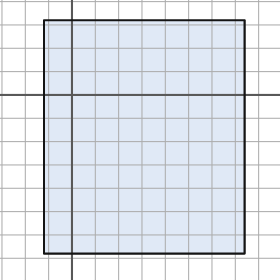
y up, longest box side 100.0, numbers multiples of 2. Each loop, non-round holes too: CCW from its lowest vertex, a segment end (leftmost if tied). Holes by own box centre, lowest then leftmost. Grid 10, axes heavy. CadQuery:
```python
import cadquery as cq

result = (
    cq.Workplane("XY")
    .moveTo(-12.0, -68.0)
    .lineTo(74.0, -68.0)
    .lineTo(74.0, 32.0)
    .lineTo(-12.0, 32.0)
    .close()
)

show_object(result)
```